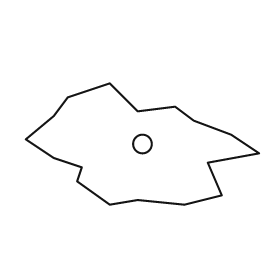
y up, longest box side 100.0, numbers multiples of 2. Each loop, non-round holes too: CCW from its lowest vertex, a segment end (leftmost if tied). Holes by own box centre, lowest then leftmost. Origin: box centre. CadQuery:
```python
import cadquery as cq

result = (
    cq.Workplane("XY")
    .moveTo(-14.0, -26.0)
    .lineTo(-2.0, -24.0)
    .lineTo(18.0, -26.0)
    .lineTo(34.0, -22.0)
    .lineTo(28.0, -8.0)
    .lineTo(50.0, -4.0)
    .lineTo(38.0, 4.0)
    .lineTo(22.0, 10.0)
    .lineTo(14.0, 16.0)
    .lineTo(-2.0, 14.0)
    .lineTo(-14.0, 26.0)
    .lineTo(-32.0, 20.0)
    .lineTo(-38.0, 12.0)
    .lineTo(-50.0, 2.0)
    .lineTo(-38.0, -6.0)
    .lineTo(-26.0, -10.0)
    .lineTo(-28.0, -16.0)
    .close()
    .moveTo(0.0, 0.0)
    .circle(4.0)
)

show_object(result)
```